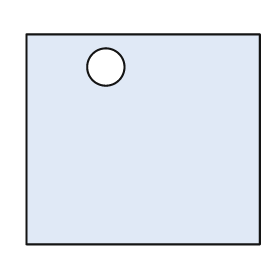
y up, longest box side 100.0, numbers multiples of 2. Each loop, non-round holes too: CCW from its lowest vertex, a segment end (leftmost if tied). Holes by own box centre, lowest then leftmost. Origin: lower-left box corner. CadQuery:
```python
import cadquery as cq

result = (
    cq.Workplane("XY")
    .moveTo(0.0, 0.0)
    .lineTo(100.0, 0.0)
    .lineTo(100.0, 90.0)
    .lineTo(0.0, 90.0)
    .close()
    .moveTo(34.0, 76.0)
    .circle(8.0)
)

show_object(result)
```